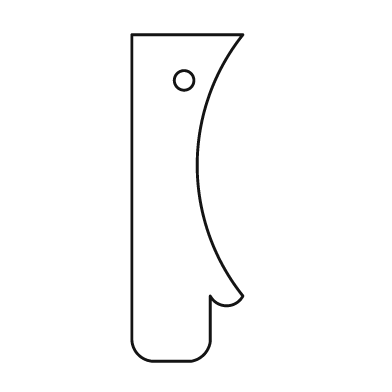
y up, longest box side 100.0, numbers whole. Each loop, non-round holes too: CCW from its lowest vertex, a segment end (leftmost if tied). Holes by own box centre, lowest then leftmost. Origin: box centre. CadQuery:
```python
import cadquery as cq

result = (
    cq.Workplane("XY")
    .moveTo(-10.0, -50.0)
    .lineTo(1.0, -50.0)
    .threePointArc((5.0, -48.0), (7.0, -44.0))
    .lineTo(7.0, -30.0)
    .threePointArc((12.0, -33.0), (17.0, -30.0))
    .threePointArc((3.0, 10.0), (17.0, 50.0))
    .lineTo(-17.0, 50.0)
    .lineTo(-17.0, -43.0)
    .threePointArc((-15.0, -48.0), (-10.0, -50.0))
    .close()
    .moveTo(-1.0, 36.0)
    .circle(3.0)
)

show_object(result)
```